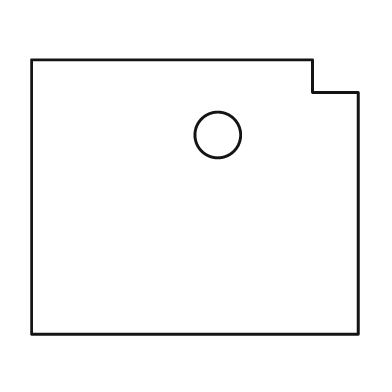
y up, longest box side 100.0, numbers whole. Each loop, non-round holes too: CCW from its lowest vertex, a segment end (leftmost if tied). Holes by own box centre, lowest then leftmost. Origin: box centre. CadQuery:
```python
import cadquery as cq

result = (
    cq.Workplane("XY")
    .moveTo(-50.0, -42.0)
    .lineTo(50.0, -42.0)
    .lineTo(50.0, 32.0)
    .lineTo(36.0, 32.0)
    .lineTo(36.0, 42.0)
    .lineTo(-50.0, 42.0)
    .close()
    .moveTo(7.0, 19.0)
    .circle(7.0)
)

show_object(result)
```